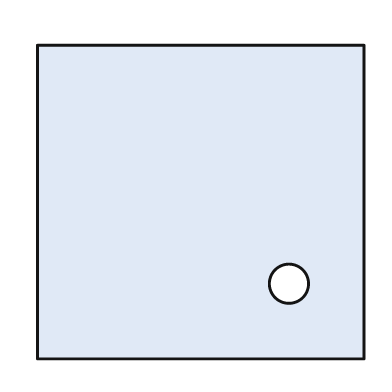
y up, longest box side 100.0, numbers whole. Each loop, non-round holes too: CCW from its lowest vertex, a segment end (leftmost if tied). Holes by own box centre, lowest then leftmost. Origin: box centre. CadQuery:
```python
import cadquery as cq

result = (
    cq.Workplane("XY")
    .moveTo(-50.0, -48.0)
    .lineTo(50.0, -48.0)
    .lineTo(50.0, 48.0)
    .lineTo(-50.0, 48.0)
    .close()
    .moveTo(27.0, -25.0)
    .circle(6.0)
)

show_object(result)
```